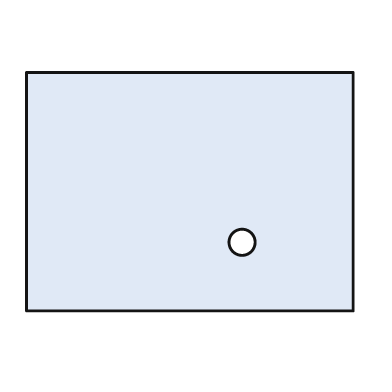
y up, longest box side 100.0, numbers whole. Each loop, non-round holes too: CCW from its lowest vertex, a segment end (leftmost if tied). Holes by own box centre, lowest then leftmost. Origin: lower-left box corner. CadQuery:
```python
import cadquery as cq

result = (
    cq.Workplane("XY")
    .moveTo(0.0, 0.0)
    .lineTo(100.0, 0.0)
    .lineTo(100.0, 73.0)
    .lineTo(0.0, 73.0)
    .close()
    .moveTo(66.0, 21.0)
    .circle(4.0)
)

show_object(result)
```